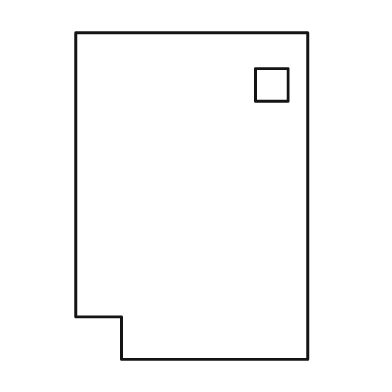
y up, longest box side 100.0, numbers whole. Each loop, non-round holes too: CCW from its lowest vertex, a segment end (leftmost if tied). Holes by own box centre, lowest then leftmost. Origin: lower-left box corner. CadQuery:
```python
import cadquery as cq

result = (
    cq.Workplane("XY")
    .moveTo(14.0, 0.0)
    .lineTo(71.0, 0.0)
    .lineTo(71.0, 100.0)
    .lineTo(0.0, 100.0)
    .lineTo(0.0, 13.0)
    .lineTo(14.0, 13.0)
    .close()
    .moveTo(55.0, 79.0)
    .lineTo(65.0, 79.0)
    .lineTo(65.0, 89.0)
    .lineTo(55.0, 89.0)
    .close()
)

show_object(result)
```